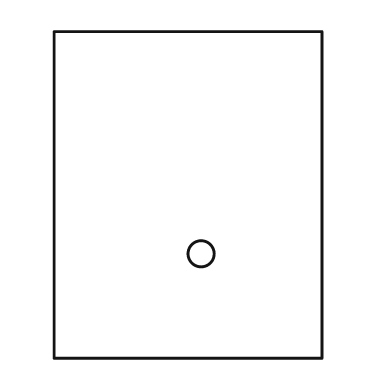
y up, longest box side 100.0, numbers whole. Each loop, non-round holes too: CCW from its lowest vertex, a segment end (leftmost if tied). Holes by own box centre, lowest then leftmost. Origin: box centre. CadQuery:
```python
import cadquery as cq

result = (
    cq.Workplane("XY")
    .moveTo(-41.0, -50.0)
    .lineTo(41.0, -50.0)
    .lineTo(41.0, 50.0)
    .lineTo(-41.0, 50.0)
    .close()
    .moveTo(4.0, -18.0)
    .circle(4.0)
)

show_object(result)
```